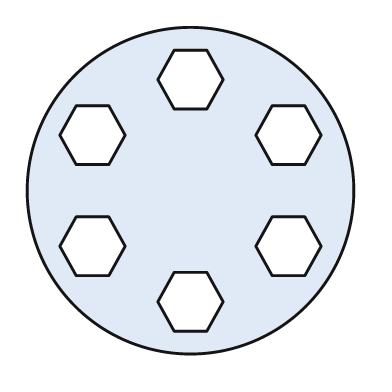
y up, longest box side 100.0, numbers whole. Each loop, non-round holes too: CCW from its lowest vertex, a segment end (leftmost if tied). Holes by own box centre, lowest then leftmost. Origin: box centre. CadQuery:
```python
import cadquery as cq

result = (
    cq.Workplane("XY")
    .moveTo(0.0, 0.0)
    .circle(50.0)
    .moveTo(-5.0, -43.0)
    .lineTo(5.0, -43.0)
    .lineTo(10.0, -34.0)
    .lineTo(5.0, -25.0)
    .lineTo(-5.0, -25.0)
    .lineTo(-10.0, -34.0)
    .close()
    .moveTo(-35.0, -26.0)
    .lineTo(-25.0, -26.0)
    .lineTo(-20.0, -17.0)
    .lineTo(-25.0, -8.0)
    .lineTo(-35.0, -8.0)
    .lineTo(-40.0, -17.0)
    .close()
    .moveTo(25.0, -26.0)
    .lineTo(35.0, -26.0)
    .lineTo(40.0, -17.0)
    .lineTo(35.0, -8.0)
    .lineTo(25.0, -8.0)
    .lineTo(20.0, -17.0)
    .close()
    .moveTo(-35.0, 8.0)
    .lineTo(-25.0, 8.0)
    .lineTo(-20.0, 17.0)
    .lineTo(-25.0, 26.0)
    .lineTo(-35.0, 26.0)
    .lineTo(-40.0, 17.0)
    .close()
    .moveTo(25.0, 8.0)
    .lineTo(35.0, 8.0)
    .lineTo(40.0, 17.0)
    .lineTo(35.0, 26.0)
    .lineTo(25.0, 26.0)
    .lineTo(20.0, 17.0)
    .close()
    .moveTo(-5.0, 25.0)
    .lineTo(5.0, 25.0)
    .lineTo(10.0, 34.0)
    .lineTo(5.0, 43.0)
    .lineTo(-5.0, 43.0)
    .lineTo(-10.0, 34.0)
    .close()
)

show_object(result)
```